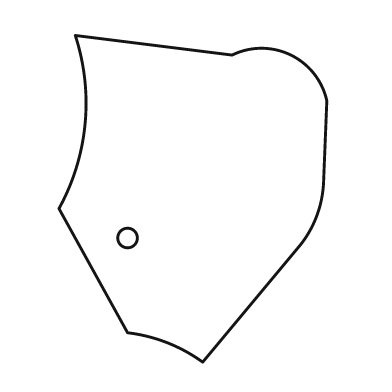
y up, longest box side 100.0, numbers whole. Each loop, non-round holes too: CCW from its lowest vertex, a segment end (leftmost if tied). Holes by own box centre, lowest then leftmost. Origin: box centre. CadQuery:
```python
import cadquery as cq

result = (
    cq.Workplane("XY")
    .moveTo(3.0, -50.0)
    .lineTo(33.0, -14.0)
    .threePointArc((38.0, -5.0), (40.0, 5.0))
    .lineTo(41.0, 30.0)
    .threePointArc((30.0, 44.0), (12.0, 44.0))
    .lineTo(-36.0, 50.0)
    .threePointArc((-33.0, 23.0), (-41.0, -3.0))
    .lineTo(-20.0, -41.0)
    .threePointArc((-8.0, -44.0), (3.0, -50.0))
    .close()
    .moveTo(-20.0, -12.0)
    .circle(3.0)
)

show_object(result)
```